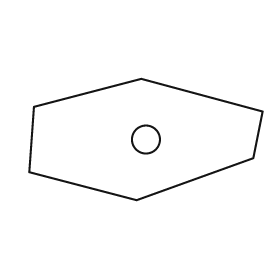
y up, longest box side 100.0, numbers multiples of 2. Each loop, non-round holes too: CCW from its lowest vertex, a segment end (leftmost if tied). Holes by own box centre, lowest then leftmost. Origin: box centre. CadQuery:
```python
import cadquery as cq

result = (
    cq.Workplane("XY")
    .moveTo(-4.0, -26.0)
    .lineTo(46.0, -8.0)
    .lineTo(50.0, 12.0)
    .lineTo(-2.0, 26.0)
    .lineTo(-48.0, 14.0)
    .lineTo(-50.0, -14.0)
    .close()
    .moveTo(0.0, 0.0)
    .circle(6.0)
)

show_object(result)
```